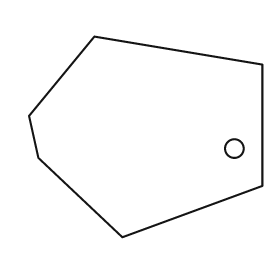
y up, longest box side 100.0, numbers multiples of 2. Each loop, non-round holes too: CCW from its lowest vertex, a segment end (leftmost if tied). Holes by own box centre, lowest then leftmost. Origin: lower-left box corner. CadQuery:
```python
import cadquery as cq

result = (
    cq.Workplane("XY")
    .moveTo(40.0, 0.0)
    .lineTo(100.0, 22.0)
    .lineTo(100.0, 74.0)
    .lineTo(28.0, 86.0)
    .lineTo(0.0, 52.0)
    .lineTo(4.0, 34.0)
    .close()
    .moveTo(88.0, 38.0)
    .circle(4.0)
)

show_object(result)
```